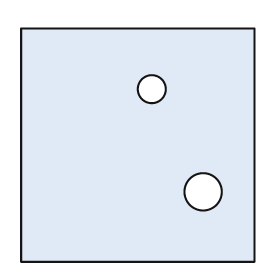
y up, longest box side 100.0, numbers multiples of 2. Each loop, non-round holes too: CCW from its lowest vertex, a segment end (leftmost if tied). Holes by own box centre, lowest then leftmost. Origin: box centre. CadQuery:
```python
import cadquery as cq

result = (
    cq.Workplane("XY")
    .moveTo(-50.0, -50.0)
    .lineTo(50.0, -50.0)
    .lineTo(50.0, 50.0)
    .lineTo(-50.0, 50.0)
    .close()
    .moveTo(28.0, -20.0)
    .circle(8.0)
    .moveTo(6.0, 24.0)
    .circle(6.0)
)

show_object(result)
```